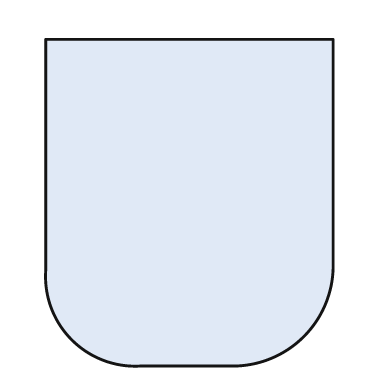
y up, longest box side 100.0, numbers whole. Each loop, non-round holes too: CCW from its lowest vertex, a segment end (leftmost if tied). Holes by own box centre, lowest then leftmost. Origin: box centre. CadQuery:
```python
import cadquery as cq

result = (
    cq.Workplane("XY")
    .moveTo(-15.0, -50.0)
    .lineTo(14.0, -50.0)
    .threePointArc((35.0, -41.0), (44.0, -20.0))
    .lineTo(44.0, 50.0)
    .lineTo(-44.0, 50.0)
    .lineTo(-44.0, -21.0)
    .threePointArc((-36.0, -42.0), (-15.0, -50.0))
    .close()
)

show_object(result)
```